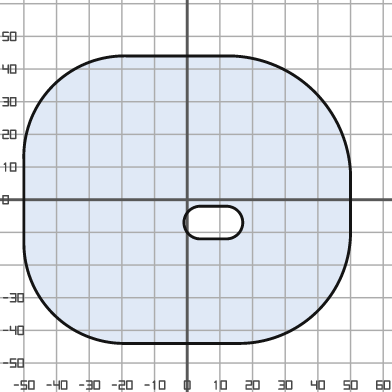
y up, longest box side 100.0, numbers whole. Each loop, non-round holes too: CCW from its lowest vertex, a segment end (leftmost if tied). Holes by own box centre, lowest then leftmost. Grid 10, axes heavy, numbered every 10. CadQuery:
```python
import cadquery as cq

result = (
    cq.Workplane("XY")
    .moveTo(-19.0, -44.0)
    .lineTo(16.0, -44.0)
    .threePointArc((40.0, -34.0), (50.0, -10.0))
    .lineTo(50.0, 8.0)
    .threePointArc((39.0, 33.0), (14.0, 44.0))
    .lineTo(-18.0, 44.0)
    .threePointArc((-41.0, 35.0), (-50.0, 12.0))
    .lineTo(-50.0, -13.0)
    .threePointArc((-41.0, -35.0), (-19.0, -44.0))
    .close()
    .moveTo(4.0, -12.0)
    .lineTo(12.0, -12.0)
    .threePointArc((17.0, -7.0), (12.0, -2.0))
    .lineTo(4.0, -2.0)
    .threePointArc((-1.0, -7.0), (4.0, -12.0))
    .close()
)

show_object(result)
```